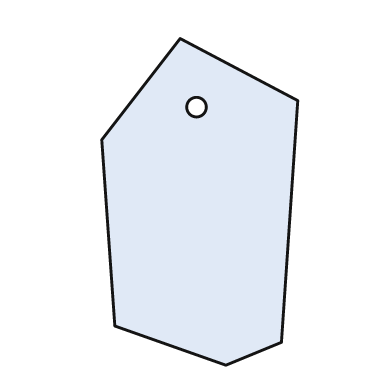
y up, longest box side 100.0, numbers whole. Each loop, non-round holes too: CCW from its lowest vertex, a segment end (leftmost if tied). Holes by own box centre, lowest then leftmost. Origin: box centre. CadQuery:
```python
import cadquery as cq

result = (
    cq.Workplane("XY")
    .moveTo(8.0, -50.0)
    .lineTo(25.0, -43.0)
    .lineTo(30.0, 31.0)
    .lineTo(-6.0, 50.0)
    .lineTo(-30.0, 19.0)
    .lineTo(-26.0, -38.0)
    .close()
    .moveTo(-1.0, 29.0)
    .circle(3.0)
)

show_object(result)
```